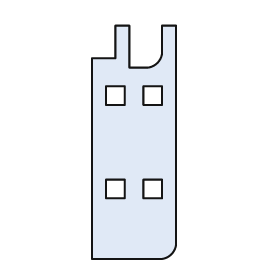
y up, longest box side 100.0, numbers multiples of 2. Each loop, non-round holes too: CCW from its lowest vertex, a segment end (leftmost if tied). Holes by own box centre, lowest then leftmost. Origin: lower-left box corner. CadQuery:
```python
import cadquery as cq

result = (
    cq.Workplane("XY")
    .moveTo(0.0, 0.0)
    .lineTo(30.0, 0.0)
    .threePointArc((34.0, 2.0), (36.0, 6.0))
    .lineTo(36.0, 100.0)
    .lineTo(30.0, 100.0)
    .lineTo(30.0, 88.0)
    .threePointArc((28.0, 84.0), (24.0, 82.0))
    .lineTo(16.0, 82.0)
    .lineTo(16.0, 100.0)
    .lineTo(10.0, 100.0)
    .lineTo(10.0, 86.0)
    .lineTo(0.0, 86.0)
    .close()
    .moveTo(6.0, 26.0)
    .lineTo(14.0, 26.0)
    .lineTo(14.0, 34.0)
    .lineTo(6.0, 34.0)
    .close()
    .moveTo(22.0, 26.0)
    .lineTo(30.0, 26.0)
    .lineTo(30.0, 34.0)
    .lineTo(22.0, 34.0)
    .close()
    .moveTo(6.0, 66.0)
    .lineTo(14.0, 66.0)
    .lineTo(14.0, 74.0)
    .lineTo(6.0, 74.0)
    .close()
    .moveTo(22.0, 66.0)
    .lineTo(30.0, 66.0)
    .lineTo(30.0, 74.0)
    .lineTo(22.0, 74.0)
    .close()
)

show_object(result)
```